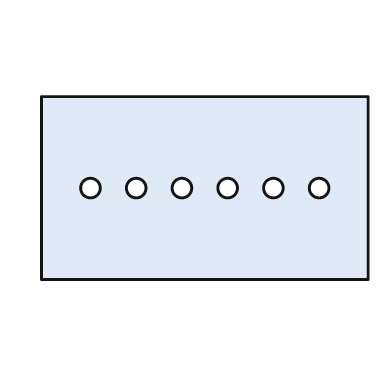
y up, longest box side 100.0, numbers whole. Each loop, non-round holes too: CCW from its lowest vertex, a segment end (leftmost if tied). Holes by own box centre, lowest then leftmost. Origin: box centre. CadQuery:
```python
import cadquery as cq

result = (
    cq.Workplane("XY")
    .moveTo(-50.0, -28.0)
    .lineTo(50.0, -28.0)
    .lineTo(50.0, 28.0)
    .lineTo(-50.0, 28.0)
    .close()
    .moveTo(-35.0, 0.0)
    .circle(3.0)
    .moveTo(-21.0, 0.0)
    .circle(3.0)
    .moveTo(-7.0, 0.0)
    .circle(3.0)
    .moveTo(7.0, 0.0)
    .circle(3.0)
    .moveTo(21.0, 0.0)
    .circle(3.0)
    .moveTo(35.0, 0.0)
    .circle(3.0)
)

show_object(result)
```